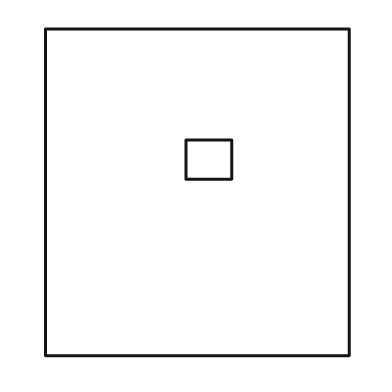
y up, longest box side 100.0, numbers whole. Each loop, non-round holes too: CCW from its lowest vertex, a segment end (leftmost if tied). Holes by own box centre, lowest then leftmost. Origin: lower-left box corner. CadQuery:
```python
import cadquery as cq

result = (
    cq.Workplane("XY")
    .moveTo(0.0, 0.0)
    .lineTo(93.0, 0.0)
    .lineTo(93.0, 100.0)
    .lineTo(0.0, 100.0)
    .close()
    .moveTo(43.0, 54.0)
    .lineTo(57.0, 54.0)
    .lineTo(57.0, 66.0)
    .lineTo(43.0, 66.0)
    .close()
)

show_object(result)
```